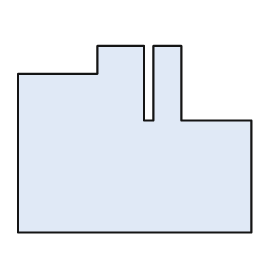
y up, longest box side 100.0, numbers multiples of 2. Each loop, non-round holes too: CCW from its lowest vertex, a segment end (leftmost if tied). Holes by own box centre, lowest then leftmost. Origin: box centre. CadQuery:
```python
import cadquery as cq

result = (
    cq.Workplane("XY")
    .moveTo(-50.0, -40.0)
    .lineTo(50.0, -40.0)
    .lineTo(50.0, 8.0)
    .lineTo(20.0, 8.0)
    .lineTo(20.0, 40.0)
    .lineTo(8.0, 40.0)
    .lineTo(8.0, 8.0)
    .lineTo(4.0, 8.0)
    .lineTo(4.0, 40.0)
    .lineTo(-16.0, 40.0)
    .lineTo(-16.0, 28.0)
    .lineTo(-50.0, 28.0)
    .close()
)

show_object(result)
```